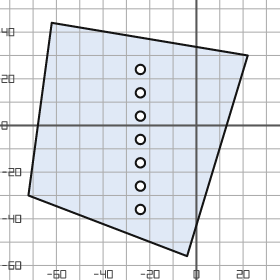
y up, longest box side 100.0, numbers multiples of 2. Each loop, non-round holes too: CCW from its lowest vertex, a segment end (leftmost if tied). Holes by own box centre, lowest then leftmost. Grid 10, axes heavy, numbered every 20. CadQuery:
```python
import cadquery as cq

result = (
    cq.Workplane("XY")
    .moveTo(-4.0, -56.0)
    .lineTo(22.0, 30.0)
    .lineTo(-62.0, 44.0)
    .lineTo(-72.0, -30.0)
    .close()
    .moveTo(-24.0, -36.0)
    .circle(2.0)
    .moveTo(-24.0, -26.0)
    .circle(2.0)
    .moveTo(-24.0, -16.0)
    .circle(2.0)
    .moveTo(-24.0, -6.0)
    .circle(2.0)
    .moveTo(-24.0, 4.0)
    .circle(2.0)
    .moveTo(-24.0, 14.0)
    .circle(2.0)
    .moveTo(-24.0, 24.0)
    .circle(2.0)
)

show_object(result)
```